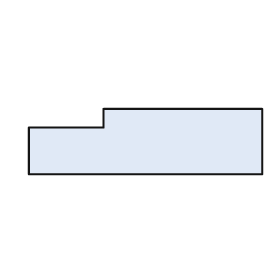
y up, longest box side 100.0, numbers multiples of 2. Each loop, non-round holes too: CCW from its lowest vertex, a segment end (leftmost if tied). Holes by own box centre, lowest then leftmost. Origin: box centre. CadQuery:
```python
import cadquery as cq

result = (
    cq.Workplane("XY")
    .moveTo(-50.0, -14.0)
    .lineTo(50.0, -14.0)
    .lineTo(50.0, 14.0)
    .lineTo(-18.0, 14.0)
    .lineTo(-18.0, 6.0)
    .lineTo(-50.0, 6.0)
    .close()
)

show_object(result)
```